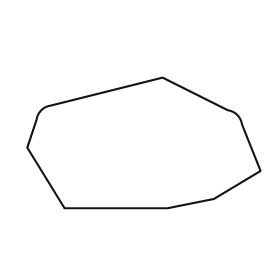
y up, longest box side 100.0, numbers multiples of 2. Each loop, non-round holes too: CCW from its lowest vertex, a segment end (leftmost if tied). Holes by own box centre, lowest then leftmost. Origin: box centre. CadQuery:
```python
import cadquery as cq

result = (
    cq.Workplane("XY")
    .moveTo(-34.0, -28.0)
    .lineTo(10.0, -28.0)
    .lineTo(30.0, -24.0)
    .lineTo(50.0, -12.0)
    .lineTo(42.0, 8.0)
    .threePointArc((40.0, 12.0), (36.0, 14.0))
    .lineTo(8.0, 28.0)
    .lineTo(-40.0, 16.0)
    .threePointArc((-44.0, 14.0), (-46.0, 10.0))
    .lineTo(-50.0, -2.0)
    .close()
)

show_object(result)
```